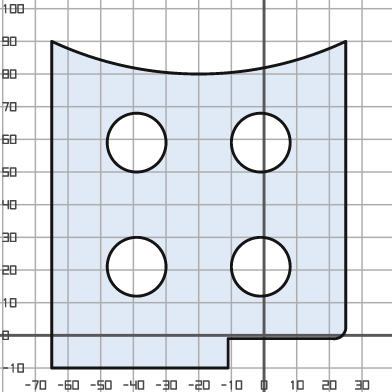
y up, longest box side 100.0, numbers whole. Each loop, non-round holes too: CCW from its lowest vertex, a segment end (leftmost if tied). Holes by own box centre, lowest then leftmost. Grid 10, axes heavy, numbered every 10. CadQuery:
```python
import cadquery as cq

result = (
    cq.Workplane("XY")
    .moveTo(-65.0, -10.0)
    .lineTo(-11.0, -10.0)
    .lineTo(-11.0, -1.0)
    .lineTo(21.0, -1.0)
    .threePointArc((24.0, 0.0), (25.0, 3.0))
    .lineTo(25.0, 90.0)
    .threePointArc((-20.0, 80.0), (-65.0, 90.0))
    .close()
    .moveTo(-39.0, 21.0)
    .circle(9.0)
    .moveTo(-1.0, 21.0)
    .circle(9.0)
    .moveTo(-39.0, 59.0)
    .circle(9.0)
    .moveTo(-1.0, 59.0)
    .circle(9.0)
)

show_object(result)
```